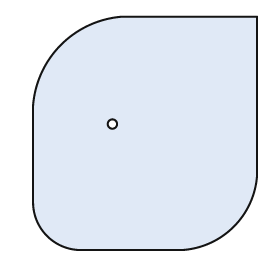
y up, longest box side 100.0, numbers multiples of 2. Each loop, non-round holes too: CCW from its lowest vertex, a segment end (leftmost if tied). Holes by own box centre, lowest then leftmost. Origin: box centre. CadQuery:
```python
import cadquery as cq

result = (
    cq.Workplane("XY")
    .moveTo(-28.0, -50.0)
    .lineTo(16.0, -50.0)
    .threePointArc((38.0, -40.0), (48.0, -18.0))
    .lineTo(48.0, 50.0)
    .lineTo(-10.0, 50.0)
    .threePointArc((-36.0, 38.0), (-48.0, 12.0))
    .lineTo(-48.0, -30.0)
    .threePointArc((-42.0, -44.0), (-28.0, -50.0))
    .close()
    .moveTo(-14.0, 4.0)
    .circle(2.0)
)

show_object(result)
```